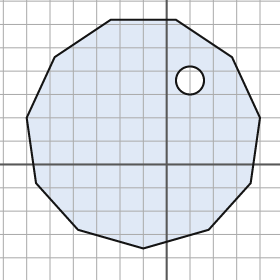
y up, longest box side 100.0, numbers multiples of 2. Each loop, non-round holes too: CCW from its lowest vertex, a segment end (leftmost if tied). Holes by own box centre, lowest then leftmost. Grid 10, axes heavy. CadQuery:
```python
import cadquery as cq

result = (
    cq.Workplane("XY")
    .moveTo(-10.0, -36.0)
    .lineTo(18.0, -28.0)
    .lineTo(36.0, -8.0)
    .lineTo(40.0, 20.0)
    .lineTo(28.0, 46.0)
    .lineTo(4.0, 62.0)
    .lineTo(-24.0, 62.0)
    .lineTo(-48.0, 46.0)
    .lineTo(-60.0, 20.0)
    .lineTo(-56.0, -8.0)
    .lineTo(-38.0, -28.0)
    .close()
    .moveTo(10.0, 36.0)
    .circle(6.0)
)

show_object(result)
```